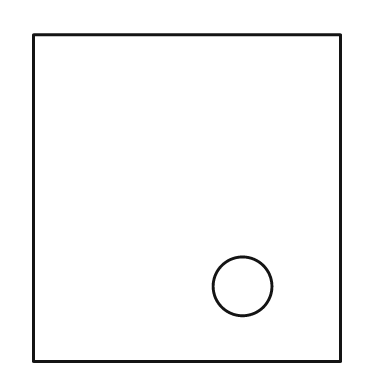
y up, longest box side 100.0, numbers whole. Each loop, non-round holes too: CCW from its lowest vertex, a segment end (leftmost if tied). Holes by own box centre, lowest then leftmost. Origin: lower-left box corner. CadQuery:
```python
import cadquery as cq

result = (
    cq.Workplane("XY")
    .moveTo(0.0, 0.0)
    .lineTo(94.0, 0.0)
    .lineTo(94.0, 100.0)
    .lineTo(0.0, 100.0)
    .close()
    .moveTo(64.0, 23.0)
    .circle(9.0)
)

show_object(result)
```